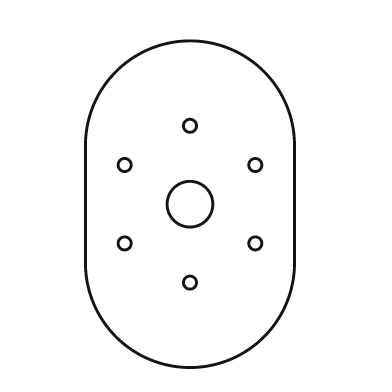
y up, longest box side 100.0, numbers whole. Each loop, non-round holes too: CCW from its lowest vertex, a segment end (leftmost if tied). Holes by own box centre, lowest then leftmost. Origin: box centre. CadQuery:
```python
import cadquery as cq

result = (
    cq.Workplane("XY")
    .moveTo(-32.0, -18.0)
    .threePointArc((0.0, -50.0), (32.0, -18.0))
    .lineTo(32.0, 18.0)
    .threePointArc((0.0, 50.0), (-32.0, 18.0))
    .close()
    .moveTo(0.0, -24.0)
    .circle(2.0)
    .moveTo(-20.0, -12.0)
    .circle(2.0)
    .moveTo(20.0, -12.0)
    .circle(2.0)
    .moveTo(0.0, 0.0)
    .circle(7.0)
    .moveTo(-20.0, 12.0)
    .circle(2.0)
    .moveTo(20.0, 12.0)
    .circle(2.0)
    .moveTo(0.0, 24.0)
    .circle(2.0)
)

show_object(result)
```